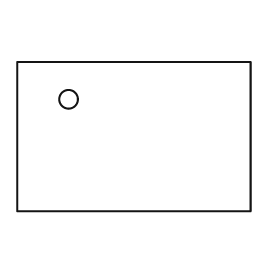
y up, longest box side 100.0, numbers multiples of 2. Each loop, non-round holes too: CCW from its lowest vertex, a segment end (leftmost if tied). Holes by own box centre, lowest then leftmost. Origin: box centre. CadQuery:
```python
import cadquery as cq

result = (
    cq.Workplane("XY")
    .moveTo(-50.0, -32.0)
    .lineTo(50.0, -32.0)
    .lineTo(50.0, 32.0)
    .lineTo(-50.0, 32.0)
    .close()
    .moveTo(-28.0, 16.0)
    .circle(4.0)
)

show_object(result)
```